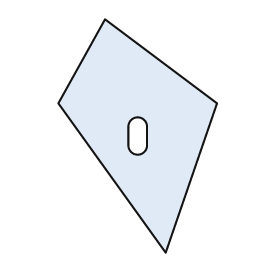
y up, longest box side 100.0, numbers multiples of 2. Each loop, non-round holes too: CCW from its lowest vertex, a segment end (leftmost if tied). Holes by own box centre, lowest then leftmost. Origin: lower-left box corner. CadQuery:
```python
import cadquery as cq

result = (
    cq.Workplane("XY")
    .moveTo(46.0, 0.0)
    .lineTo(68.0, 64.0)
    .lineTo(20.0, 100.0)
    .lineTo(0.0, 64.0)
    .close()
    .moveTo(30.0, 46.0)
    .threePointArc((34.0, 42.0), (38.0, 46.0))
    .lineTo(38.0, 54.0)
    .threePointArc((34.0, 58.0), (30.0, 54.0))
    .close()
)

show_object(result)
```